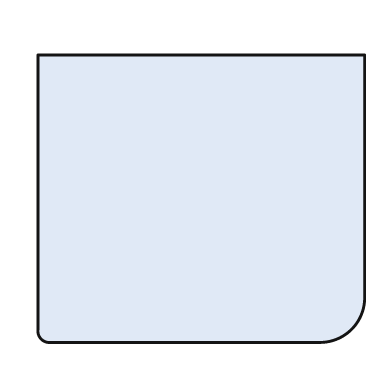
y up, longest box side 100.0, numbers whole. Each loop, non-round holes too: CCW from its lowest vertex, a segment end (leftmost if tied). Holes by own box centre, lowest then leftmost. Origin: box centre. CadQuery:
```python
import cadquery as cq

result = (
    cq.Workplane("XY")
    .moveTo(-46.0, -44.0)
    .lineTo(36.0, -44.0)
    .threePointArc((46.0, -40.0), (50.0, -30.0))
    .lineTo(50.0, 44.0)
    .lineTo(-50.0, 44.0)
    .lineTo(-50.0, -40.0)
    .threePointArc((-49.0, -43.0), (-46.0, -44.0))
    .close()
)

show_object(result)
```